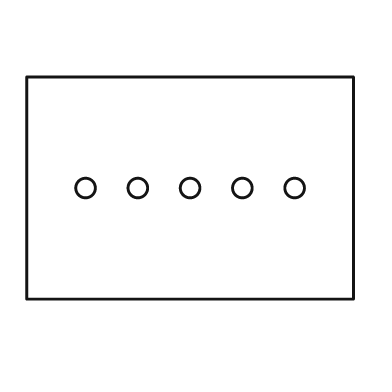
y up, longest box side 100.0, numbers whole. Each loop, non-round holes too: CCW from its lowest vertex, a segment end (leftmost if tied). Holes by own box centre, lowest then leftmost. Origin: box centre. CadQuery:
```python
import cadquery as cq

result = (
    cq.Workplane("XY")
    .moveTo(-50.0, -34.0)
    .lineTo(50.0, -34.0)
    .lineTo(50.0, 34.0)
    .lineTo(-50.0, 34.0)
    .close()
    .moveTo(-32.0, 0.0)
    .circle(3.0)
    .moveTo(-16.0, 0.0)
    .circle(3.0)
    .moveTo(0.0, 0.0)
    .circle(3.0)
    .moveTo(16.0, 0.0)
    .circle(3.0)
    .moveTo(32.0, 0.0)
    .circle(3.0)
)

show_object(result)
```